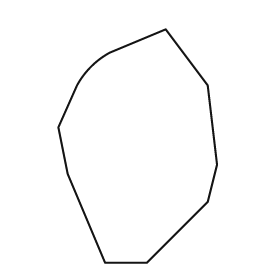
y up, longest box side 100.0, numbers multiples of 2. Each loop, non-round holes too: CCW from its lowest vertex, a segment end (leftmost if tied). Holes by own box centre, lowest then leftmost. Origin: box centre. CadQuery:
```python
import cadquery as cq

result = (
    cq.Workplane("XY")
    .moveTo(-14.0, -50.0)
    .lineTo(4.0, -50.0)
    .lineTo(30.0, -24.0)
    .lineTo(34.0, -8.0)
    .lineTo(30.0, 26.0)
    .lineTo(12.0, 50.0)
    .lineTo(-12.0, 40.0)
    .threePointArc((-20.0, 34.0), (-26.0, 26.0))
    .lineTo(-34.0, 8.0)
    .lineTo(-30.0, -12.0)
    .close()
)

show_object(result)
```